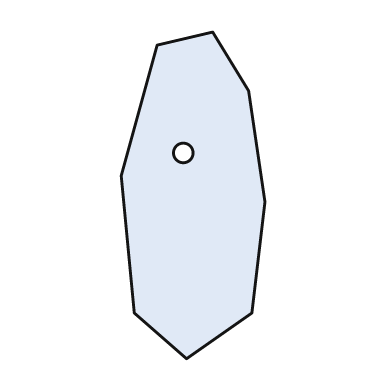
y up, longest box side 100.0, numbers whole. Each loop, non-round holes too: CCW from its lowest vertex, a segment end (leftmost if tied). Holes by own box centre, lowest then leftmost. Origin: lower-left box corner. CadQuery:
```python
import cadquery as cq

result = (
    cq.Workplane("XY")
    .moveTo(20.0, 0.0)
    .lineTo(40.0, 14.0)
    .lineTo(44.0, 48.0)
    .lineTo(39.0, 82.0)
    .lineTo(28.0, 100.0)
    .lineTo(11.0, 96.0)
    .lineTo(0.0, 56.0)
    .lineTo(4.0, 14.0)
    .close()
    .moveTo(19.0, 63.0)
    .circle(3.0)
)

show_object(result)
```